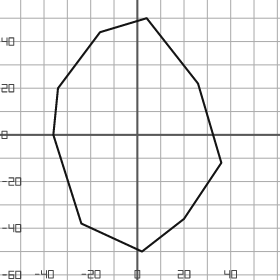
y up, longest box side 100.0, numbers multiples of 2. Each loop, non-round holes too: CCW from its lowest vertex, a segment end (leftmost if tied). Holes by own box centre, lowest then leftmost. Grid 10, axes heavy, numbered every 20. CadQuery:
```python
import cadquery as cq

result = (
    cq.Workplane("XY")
    .moveTo(2.0, -50.0)
    .lineTo(20.0, -36.0)
    .lineTo(36.0, -12.0)
    .lineTo(26.0, 22.0)
    .lineTo(4.0, 50.0)
    .lineTo(-16.0, 44.0)
    .lineTo(-34.0, 20.0)
    .lineTo(-36.0, 0.0)
    .lineTo(-24.0, -38.0)
    .close()
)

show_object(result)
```